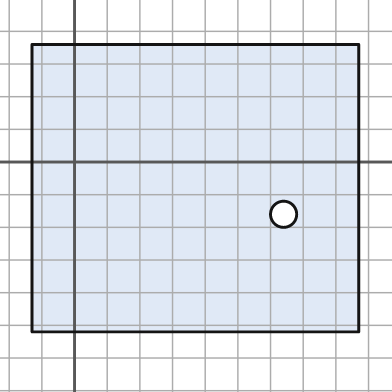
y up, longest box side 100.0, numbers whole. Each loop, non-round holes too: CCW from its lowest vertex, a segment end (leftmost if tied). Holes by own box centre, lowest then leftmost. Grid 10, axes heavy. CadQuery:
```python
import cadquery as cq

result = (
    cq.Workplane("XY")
    .moveTo(-13.0, -52.0)
    .lineTo(87.0, -52.0)
    .lineTo(87.0, 36.0)
    .lineTo(-13.0, 36.0)
    .close()
    .moveTo(64.0, -16.0)
    .circle(4.0)
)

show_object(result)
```